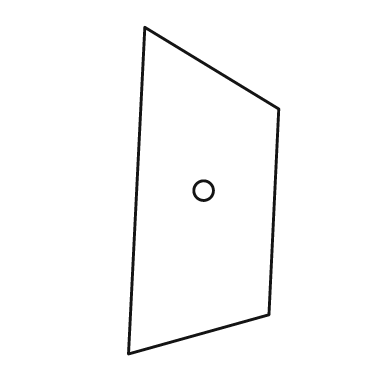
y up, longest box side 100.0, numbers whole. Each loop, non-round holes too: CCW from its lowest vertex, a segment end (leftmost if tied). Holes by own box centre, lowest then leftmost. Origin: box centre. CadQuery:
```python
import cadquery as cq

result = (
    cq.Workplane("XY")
    .moveTo(-23.0, -50.0)
    .lineTo(20.0, -38.0)
    .lineTo(23.0, 25.0)
    .lineTo(-18.0, 50.0)
    .close()
    .moveTo(0.0, 0.0)
    .circle(3.0)
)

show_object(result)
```